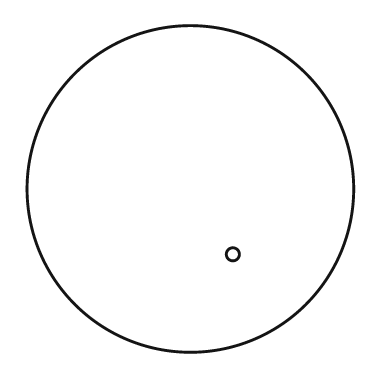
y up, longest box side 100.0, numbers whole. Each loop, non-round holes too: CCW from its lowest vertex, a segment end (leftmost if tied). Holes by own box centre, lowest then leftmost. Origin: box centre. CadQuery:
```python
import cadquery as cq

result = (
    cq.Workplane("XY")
    .moveTo(0.0, 0.0)
    .circle(50.0)
    .moveTo(13.0, -20.0)
    .circle(2.0)
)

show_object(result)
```